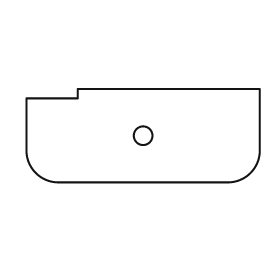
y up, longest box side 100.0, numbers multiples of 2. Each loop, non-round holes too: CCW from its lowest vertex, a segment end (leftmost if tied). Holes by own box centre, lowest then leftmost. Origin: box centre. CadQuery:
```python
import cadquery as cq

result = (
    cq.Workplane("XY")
    .moveTo(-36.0, -20.0)
    .lineTo(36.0, -20.0)
    .threePointArc((46.0, -16.0), (50.0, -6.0))
    .lineTo(50.0, 20.0)
    .lineTo(-28.0, 20.0)
    .lineTo(-28.0, 16.0)
    .lineTo(-50.0, 16.0)
    .lineTo(-50.0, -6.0)
    .threePointArc((-46.0, -16.0), (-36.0, -20.0))
    .close()
    .moveTo(0.0, 0.0)
    .circle(4.0)
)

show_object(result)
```